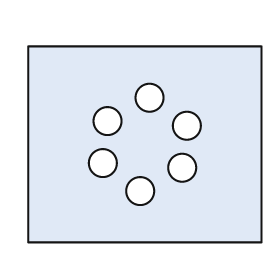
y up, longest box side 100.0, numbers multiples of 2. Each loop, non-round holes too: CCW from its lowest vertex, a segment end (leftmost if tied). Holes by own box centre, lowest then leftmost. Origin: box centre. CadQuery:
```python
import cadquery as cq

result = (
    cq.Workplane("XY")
    .moveTo(-50.0, -42.0)
    .lineTo(50.0, -42.0)
    .lineTo(50.0, 42.0)
    .lineTo(-50.0, 42.0)
    .close()
    .moveTo(-2.0, -20.0)
    .circle(6.0)
    .moveTo(16.0, -10.0)
    .circle(6.0)
    .moveTo(-18.0, -8.0)
    .circle(6.0)
    .moveTo(18.0, 8.0)
    .circle(6.0)
    .moveTo(-16.0, 10.0)
    .circle(6.0)
    .moveTo(2.0, 20.0)
    .circle(6.0)
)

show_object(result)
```